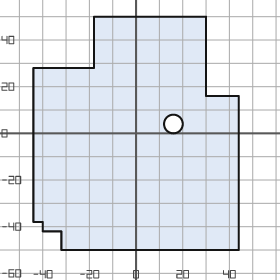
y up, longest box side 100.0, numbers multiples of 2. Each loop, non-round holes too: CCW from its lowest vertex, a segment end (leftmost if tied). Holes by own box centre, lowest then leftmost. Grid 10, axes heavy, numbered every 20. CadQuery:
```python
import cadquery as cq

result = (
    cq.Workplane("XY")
    .moveTo(-32.0, -50.0)
    .lineTo(44.0, -50.0)
    .lineTo(44.0, 16.0)
    .lineTo(30.0, 16.0)
    .lineTo(30.0, 50.0)
    .lineTo(-18.0, 50.0)
    .lineTo(-18.0, 28.0)
    .lineTo(-44.0, 28.0)
    .lineTo(-44.0, -38.0)
    .lineTo(-40.0, -38.0)
    .lineTo(-40.0, -42.0)
    .lineTo(-32.0, -42.0)
    .close()
    .moveTo(16.0, 4.0)
    .circle(4.0)
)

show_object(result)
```